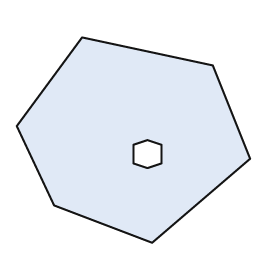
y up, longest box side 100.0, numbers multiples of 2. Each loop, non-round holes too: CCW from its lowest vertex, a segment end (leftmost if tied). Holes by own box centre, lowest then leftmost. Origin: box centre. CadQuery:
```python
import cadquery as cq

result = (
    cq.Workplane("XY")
    .moveTo(8.0, -44.0)
    .lineTo(50.0, -8.0)
    .lineTo(34.0, 32.0)
    .lineTo(-22.0, 44.0)
    .lineTo(-50.0, 6.0)
    .lineTo(-34.0, -28.0)
    .close()
    .moveTo(6.0, -12.0)
    .lineTo(12.0, -10.0)
    .lineTo(12.0, -2.0)
    .lineTo(6.0, 0.0)
    .lineTo(0.0, -2.0)
    .lineTo(0.0, -10.0)
    .close()
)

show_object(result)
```